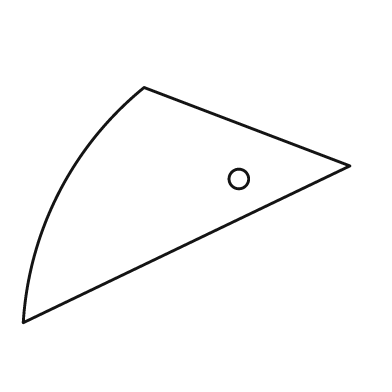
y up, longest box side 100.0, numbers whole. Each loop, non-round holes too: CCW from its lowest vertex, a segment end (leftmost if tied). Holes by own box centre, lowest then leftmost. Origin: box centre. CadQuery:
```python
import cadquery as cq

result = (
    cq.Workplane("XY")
    .moveTo(-50.0, -36.0)
    .lineTo(50.0, 12.0)
    .lineTo(-13.0, 36.0)
    .threePointArc((-39.0, 4.0), (-50.0, -36.0))
    .close()
    .moveTo(16.0, 8.0)
    .circle(3.0)
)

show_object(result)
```